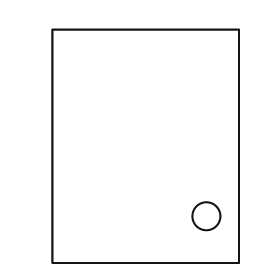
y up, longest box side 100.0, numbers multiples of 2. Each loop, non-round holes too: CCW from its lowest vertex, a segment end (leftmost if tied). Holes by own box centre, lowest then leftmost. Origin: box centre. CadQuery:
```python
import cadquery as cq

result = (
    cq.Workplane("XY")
    .moveTo(-40.0, -50.0)
    .lineTo(40.0, -50.0)
    .lineTo(40.0, 50.0)
    .lineTo(-40.0, 50.0)
    .close()
    .moveTo(26.0, -30.0)
    .circle(6.0)
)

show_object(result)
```